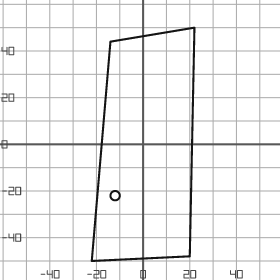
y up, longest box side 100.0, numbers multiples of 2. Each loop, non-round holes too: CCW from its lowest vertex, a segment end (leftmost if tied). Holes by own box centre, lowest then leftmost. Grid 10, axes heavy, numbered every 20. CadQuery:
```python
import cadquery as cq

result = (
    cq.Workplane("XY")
    .moveTo(-22.0, -50.0)
    .lineTo(20.0, -48.0)
    .lineTo(22.0, 50.0)
    .lineTo(-14.0, 44.0)
    .close()
    .moveTo(-12.0, -22.0)
    .circle(2.0)
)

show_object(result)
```